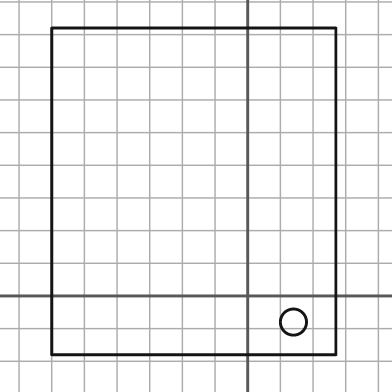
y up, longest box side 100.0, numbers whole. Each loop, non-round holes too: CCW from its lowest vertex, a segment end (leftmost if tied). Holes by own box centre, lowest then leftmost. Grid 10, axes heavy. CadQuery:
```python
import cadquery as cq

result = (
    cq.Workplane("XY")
    .moveTo(-60.0, -18.0)
    .lineTo(27.0, -18.0)
    .lineTo(27.0, 82.0)
    .lineTo(-60.0, 82.0)
    .close()
    .moveTo(14.0, -8.0)
    .circle(4.0)
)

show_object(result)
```